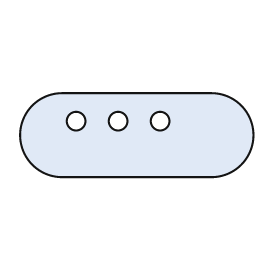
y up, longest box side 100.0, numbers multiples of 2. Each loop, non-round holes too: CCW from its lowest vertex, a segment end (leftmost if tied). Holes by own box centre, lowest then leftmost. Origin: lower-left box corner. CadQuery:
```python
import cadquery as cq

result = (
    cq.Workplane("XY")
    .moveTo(18.0, 0.0)
    .lineTo(82.0, 0.0)
    .threePointArc((100.0, 18.0), (82.0, 36.0))
    .lineTo(18.0, 36.0)
    .threePointArc((0.0, 18.0), (18.0, 0.0))
    .close()
    .moveTo(24.0, 24.0)
    .circle(4.0)
    .moveTo(42.0, 24.0)
    .circle(4.0)
    .moveTo(60.0, 24.0)
    .circle(4.0)
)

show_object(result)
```